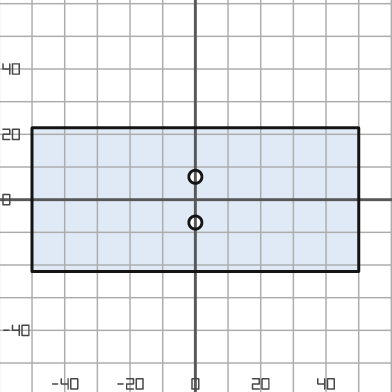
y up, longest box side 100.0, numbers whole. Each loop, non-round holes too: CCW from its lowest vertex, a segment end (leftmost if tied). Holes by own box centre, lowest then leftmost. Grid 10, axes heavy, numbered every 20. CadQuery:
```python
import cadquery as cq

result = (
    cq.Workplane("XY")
    .moveTo(-50.0, -22.0)
    .lineTo(50.0, -22.0)
    .lineTo(50.0, 22.0)
    .lineTo(-50.0, 22.0)
    .close()
    .moveTo(0.0, -7.0)
    .circle(2.0)
    .moveTo(0.0, 7.0)
    .circle(2.0)
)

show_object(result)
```